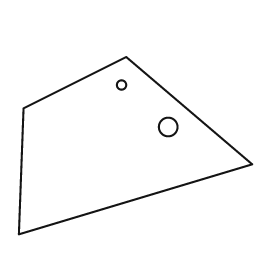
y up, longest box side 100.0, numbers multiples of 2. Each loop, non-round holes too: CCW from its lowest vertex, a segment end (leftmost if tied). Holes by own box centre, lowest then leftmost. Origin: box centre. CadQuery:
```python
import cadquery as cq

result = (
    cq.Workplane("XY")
    .moveTo(-50.0, -38.0)
    .lineTo(50.0, -8.0)
    .lineTo(-4.0, 38.0)
    .lineTo(-48.0, 16.0)
    .close()
    .moveTo(14.0, 8.0)
    .circle(4.0)
    .moveTo(-6.0, 26.0)
    .circle(2.0)
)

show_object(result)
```